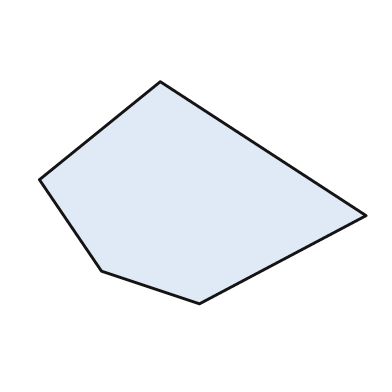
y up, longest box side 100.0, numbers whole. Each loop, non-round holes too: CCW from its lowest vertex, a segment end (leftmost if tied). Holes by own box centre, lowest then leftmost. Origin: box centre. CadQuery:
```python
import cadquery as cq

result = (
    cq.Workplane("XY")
    .moveTo(-1.0, -34.0)
    .lineTo(50.0, -7.0)
    .lineTo(-13.0, 34.0)
    .lineTo(-50.0, 4.0)
    .lineTo(-31.0, -24.0)
    .close()
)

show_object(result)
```